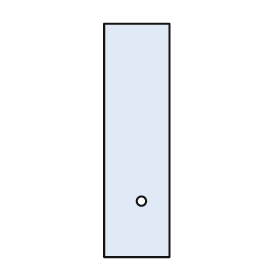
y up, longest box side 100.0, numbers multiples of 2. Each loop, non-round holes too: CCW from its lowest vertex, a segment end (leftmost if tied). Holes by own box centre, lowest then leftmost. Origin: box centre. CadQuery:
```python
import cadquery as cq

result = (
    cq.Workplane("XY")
    .moveTo(-14.0, -50.0)
    .lineTo(14.0, -50.0)
    .lineTo(14.0, 50.0)
    .lineTo(-14.0, 50.0)
    .close()
    .moveTo(2.0, -26.0)
    .circle(2.0)
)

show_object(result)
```